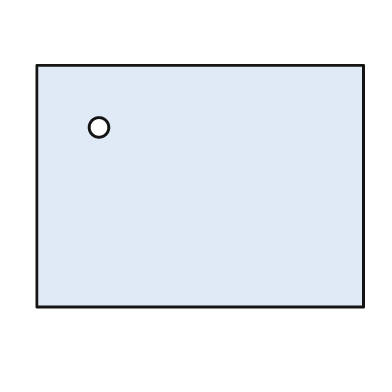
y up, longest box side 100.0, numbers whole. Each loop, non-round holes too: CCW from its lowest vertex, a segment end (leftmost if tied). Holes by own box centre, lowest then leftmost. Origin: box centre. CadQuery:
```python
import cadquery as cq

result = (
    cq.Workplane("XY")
    .moveTo(-50.0, -37.0)
    .lineTo(50.0, -37.0)
    .lineTo(50.0, 37.0)
    .lineTo(-50.0, 37.0)
    .close()
    .moveTo(-31.0, 18.0)
    .circle(3.0)
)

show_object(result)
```